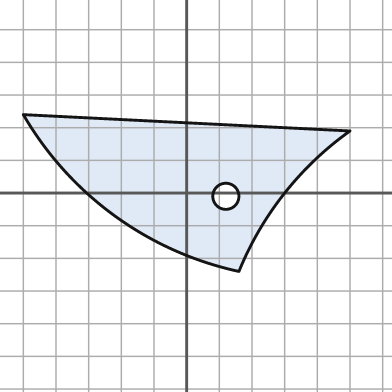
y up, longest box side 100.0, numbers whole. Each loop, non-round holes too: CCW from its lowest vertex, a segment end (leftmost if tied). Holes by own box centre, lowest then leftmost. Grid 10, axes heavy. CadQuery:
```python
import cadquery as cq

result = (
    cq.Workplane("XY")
    .moveTo(16.0, -24.0)
    .threePointArc((30.0, 0.0), (50.0, 19.0))
    .lineTo(-50.0, 24.0)
    .threePointArc((-22.0, -7.0), (16.0, -24.0))
    .close()
    .moveTo(12.0, -1.0)
    .circle(4.0)
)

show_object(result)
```